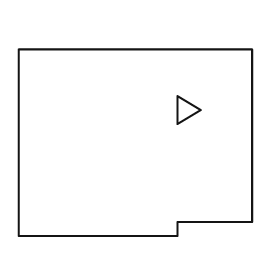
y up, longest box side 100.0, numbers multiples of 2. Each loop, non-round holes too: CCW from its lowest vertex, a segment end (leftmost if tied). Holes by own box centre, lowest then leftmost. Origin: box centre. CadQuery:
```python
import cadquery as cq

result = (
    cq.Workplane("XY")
    .moveTo(-50.0, -40.0)
    .lineTo(18.0, -40.0)
    .lineTo(18.0, -34.0)
    .lineTo(50.0, -34.0)
    .lineTo(50.0, 40.0)
    .lineTo(-50.0, 40.0)
    .close()
    .moveTo(18.0, 8.0)
    .lineTo(28.0, 14.0)
    .lineTo(18.0, 20.0)
    .close()
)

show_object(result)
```